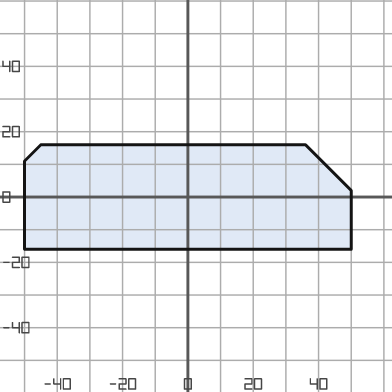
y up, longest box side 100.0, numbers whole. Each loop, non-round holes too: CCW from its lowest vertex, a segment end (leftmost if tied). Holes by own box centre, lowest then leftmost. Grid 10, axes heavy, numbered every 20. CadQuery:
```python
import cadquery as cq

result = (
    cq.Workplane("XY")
    .moveTo(-50.0, -16.0)
    .lineTo(50.0, -16.0)
    .lineTo(50.0, 2.0)
    .lineTo(36.0, 16.0)
    .lineTo(-45.0, 16.0)
    .lineTo(-50.0, 11.0)
    .close()
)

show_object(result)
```